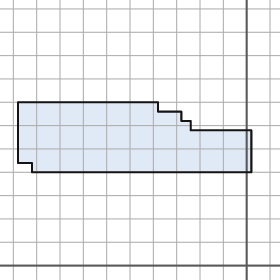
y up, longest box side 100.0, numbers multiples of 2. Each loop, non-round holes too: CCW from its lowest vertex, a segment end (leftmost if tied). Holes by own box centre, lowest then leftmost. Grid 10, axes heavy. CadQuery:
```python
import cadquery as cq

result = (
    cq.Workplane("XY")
    .moveTo(-92.0, 40.0)
    .lineTo(2.0, 40.0)
    .lineTo(2.0, 58.0)
    .lineTo(-24.0, 58.0)
    .lineTo(-24.0, 62.0)
    .lineTo(-28.0, 62.0)
    .lineTo(-28.0, 66.0)
    .lineTo(-38.0, 66.0)
    .lineTo(-38.0, 70.0)
    .lineTo(-98.0, 70.0)
    .lineTo(-98.0, 44.0)
    .lineTo(-92.0, 44.0)
    .close()
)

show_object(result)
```